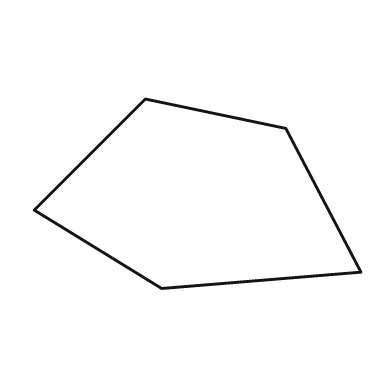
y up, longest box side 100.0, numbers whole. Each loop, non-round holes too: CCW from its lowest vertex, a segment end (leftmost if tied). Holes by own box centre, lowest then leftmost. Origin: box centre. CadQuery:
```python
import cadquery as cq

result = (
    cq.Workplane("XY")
    .moveTo(-11.0, -29.0)
    .lineTo(50.0, -24.0)
    .lineTo(27.0, 20.0)
    .lineTo(-16.0, 29.0)
    .lineTo(-50.0, -5.0)
    .close()
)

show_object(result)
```